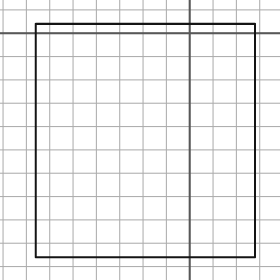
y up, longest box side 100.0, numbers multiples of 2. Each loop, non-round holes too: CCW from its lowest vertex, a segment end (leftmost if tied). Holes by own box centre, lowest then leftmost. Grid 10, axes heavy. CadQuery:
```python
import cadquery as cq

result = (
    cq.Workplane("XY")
    .moveTo(-66.0, -96.0)
    .lineTo(28.0, -96.0)
    .lineTo(28.0, 4.0)
    .lineTo(-66.0, 4.0)
    .close()
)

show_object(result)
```